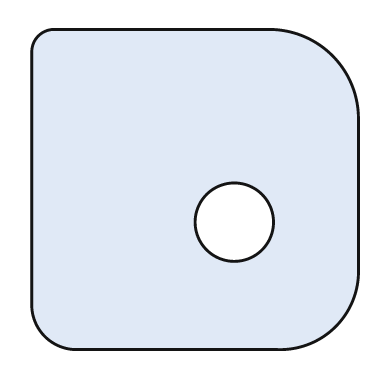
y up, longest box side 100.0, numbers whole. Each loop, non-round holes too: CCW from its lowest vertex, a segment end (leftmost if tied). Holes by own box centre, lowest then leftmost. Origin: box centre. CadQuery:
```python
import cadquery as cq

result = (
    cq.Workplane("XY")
    .moveTo(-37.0, -49.0)
    .lineTo(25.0, -49.0)
    .threePointArc((43.0, -42.0), (50.0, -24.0))
    .lineTo(50.0, 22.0)
    .threePointArc((42.0, 41.0), (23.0, 49.0))
    .lineTo(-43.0, 49.0)
    .threePointArc((-48.0, 47.0), (-50.0, 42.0))
    .lineTo(-50.0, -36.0)
    .threePointArc((-46.0, -45.0), (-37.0, -49.0))
    .close()
    .moveTo(12.0, -10.0)
    .circle(12.0)
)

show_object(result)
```